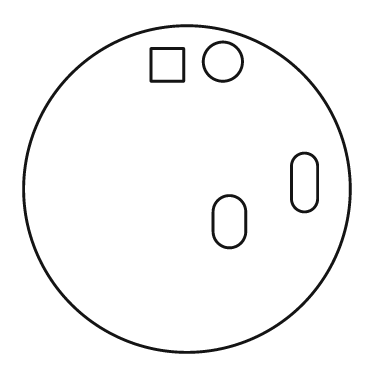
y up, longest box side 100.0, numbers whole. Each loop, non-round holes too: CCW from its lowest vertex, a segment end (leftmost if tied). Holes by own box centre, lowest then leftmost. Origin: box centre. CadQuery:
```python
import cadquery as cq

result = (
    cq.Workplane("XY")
    .moveTo(0.0, 0.0)
    .circle(50.0)
    .moveTo(8.0, -13.0)
    .threePointArc((13.0, -18.0), (18.0, -13.0))
    .lineTo(18.0, -7.0)
    .threePointArc((13.0, -2.0), (8.0, -7.0))
    .close()
    .moveTo(32.0, -3.0)
    .threePointArc((36.0, -7.0), (40.0, -3.0))
    .lineTo(40.0, 7.0)
    .threePointArc((36.0, 11.0), (32.0, 7.0))
    .close()
    .moveTo(-11.0, 33.0)
    .lineTo(-1.0, 33.0)
    .lineTo(-1.0, 43.0)
    .lineTo(-11.0, 43.0)
    .close()
    .moveTo(11.0, 39.0)
    .circle(6.0)
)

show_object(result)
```